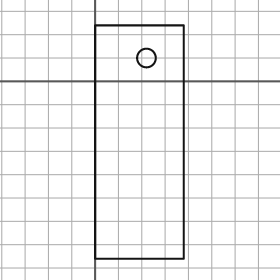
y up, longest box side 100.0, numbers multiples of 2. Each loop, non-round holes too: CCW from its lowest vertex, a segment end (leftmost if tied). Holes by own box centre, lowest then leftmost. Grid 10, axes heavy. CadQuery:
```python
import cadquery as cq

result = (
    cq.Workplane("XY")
    .moveTo(0.0, -76.0)
    .lineTo(38.0, -76.0)
    .lineTo(38.0, 24.0)
    .lineTo(0.0, 24.0)
    .close()
    .moveTo(22.0, 10.0)
    .circle(4.0)
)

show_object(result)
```